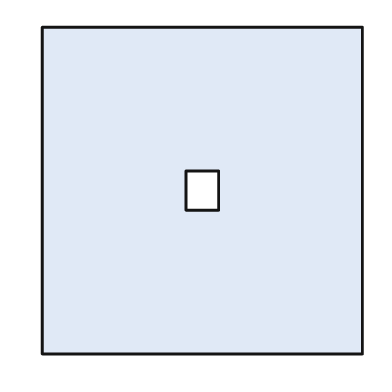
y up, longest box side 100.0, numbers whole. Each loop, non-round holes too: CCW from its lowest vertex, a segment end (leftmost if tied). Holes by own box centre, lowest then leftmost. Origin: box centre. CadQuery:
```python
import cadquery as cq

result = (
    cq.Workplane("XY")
    .moveTo(-49.0, -50.0)
    .lineTo(49.0, -50.0)
    .lineTo(49.0, 50.0)
    .lineTo(-49.0, 50.0)
    .close()
    .moveTo(-5.0, -6.0)
    .lineTo(5.0, -6.0)
    .lineTo(5.0, 6.0)
    .lineTo(-5.0, 6.0)
    .close()
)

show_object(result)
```